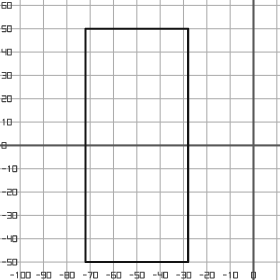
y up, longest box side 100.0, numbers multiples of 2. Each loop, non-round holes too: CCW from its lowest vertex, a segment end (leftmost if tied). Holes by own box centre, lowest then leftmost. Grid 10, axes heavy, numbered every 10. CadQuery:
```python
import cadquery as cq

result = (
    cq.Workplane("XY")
    .moveTo(-72.0, -50.0)
    .lineTo(-28.0, -50.0)
    .lineTo(-28.0, 50.0)
    .lineTo(-72.0, 50.0)
    .close()
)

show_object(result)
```